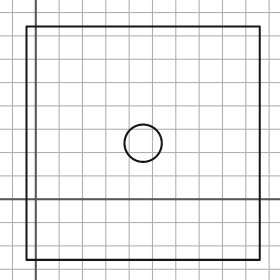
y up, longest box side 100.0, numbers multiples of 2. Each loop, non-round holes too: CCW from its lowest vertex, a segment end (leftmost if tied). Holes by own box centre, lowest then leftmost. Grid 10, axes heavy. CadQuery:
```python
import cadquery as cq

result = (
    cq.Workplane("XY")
    .moveTo(-4.0, -26.0)
    .lineTo(96.0, -26.0)
    .lineTo(96.0, 74.0)
    .lineTo(-4.0, 74.0)
    .close()
    .moveTo(46.0, 24.0)
    .circle(8.0)
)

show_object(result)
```